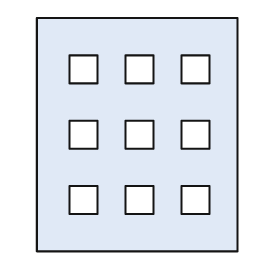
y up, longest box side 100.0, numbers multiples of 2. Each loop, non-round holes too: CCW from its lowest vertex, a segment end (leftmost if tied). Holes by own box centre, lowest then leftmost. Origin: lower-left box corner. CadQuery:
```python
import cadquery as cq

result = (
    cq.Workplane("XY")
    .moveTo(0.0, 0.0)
    .lineTo(86.0, 0.0)
    .lineTo(86.0, 100.0)
    .lineTo(0.0, 100.0)
    .close()
    .moveTo(14.0, 16.0)
    .lineTo(26.0, 16.0)
    .lineTo(26.0, 28.0)
    .lineTo(14.0, 28.0)
    .close()
    .moveTo(38.0, 16.0)
    .lineTo(50.0, 16.0)
    .lineTo(50.0, 28.0)
    .lineTo(38.0, 28.0)
    .close()
    .moveTo(62.0, 16.0)
    .lineTo(74.0, 16.0)
    .lineTo(74.0, 28.0)
    .lineTo(62.0, 28.0)
    .close()
    .moveTo(14.0, 44.0)
    .lineTo(26.0, 44.0)
    .lineTo(26.0, 56.0)
    .lineTo(14.0, 56.0)
    .close()
    .moveTo(38.0, 44.0)
    .lineTo(50.0, 44.0)
    .lineTo(50.0, 56.0)
    .lineTo(38.0, 56.0)
    .close()
    .moveTo(62.0, 44.0)
    .lineTo(74.0, 44.0)
    .lineTo(74.0, 56.0)
    .lineTo(62.0, 56.0)
    .close()
    .moveTo(14.0, 72.0)
    .lineTo(26.0, 72.0)
    .lineTo(26.0, 84.0)
    .lineTo(14.0, 84.0)
    .close()
    .moveTo(38.0, 72.0)
    .lineTo(50.0, 72.0)
    .lineTo(50.0, 84.0)
    .lineTo(38.0, 84.0)
    .close()
    .moveTo(62.0, 72.0)
    .lineTo(74.0, 72.0)
    .lineTo(74.0, 84.0)
    .lineTo(62.0, 84.0)
    .close()
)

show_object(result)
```